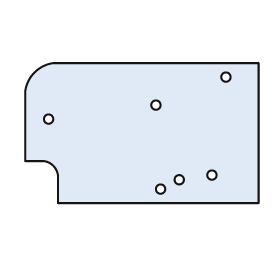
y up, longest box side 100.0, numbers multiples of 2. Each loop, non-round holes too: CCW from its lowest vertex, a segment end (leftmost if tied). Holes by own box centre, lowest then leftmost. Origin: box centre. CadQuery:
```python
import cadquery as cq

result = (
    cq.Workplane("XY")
    .moveTo(-36.0, -30.0)
    .lineTo(50.0, -30.0)
    .lineTo(50.0, 30.0)
    .lineTo(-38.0, 30.0)
    .threePointArc((-46.0, 26.0), (-50.0, 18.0))
    .lineTo(-50.0, -12.0)
    .lineTo(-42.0, -12.0)
    .threePointArc((-38.0, -14.0), (-36.0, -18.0))
    .close()
    .moveTo(8.0, -24.0)
    .circle(2.0)
    .moveTo(16.0, -20.0)
    .circle(2.0)
    .moveTo(30.0, -18.0)
    .circle(2.0)
    .moveTo(-40.0, 6.0)
    .circle(2.0)
    .moveTo(6.0, 12.0)
    .circle(2.0)
    .moveTo(36.0, 24.0)
    .circle(2.0)
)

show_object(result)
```